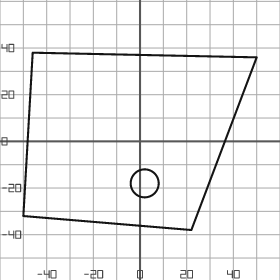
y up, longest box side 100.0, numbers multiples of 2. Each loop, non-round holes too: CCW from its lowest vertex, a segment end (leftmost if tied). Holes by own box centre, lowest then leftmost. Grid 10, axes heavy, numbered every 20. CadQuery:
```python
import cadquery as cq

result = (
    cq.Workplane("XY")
    .moveTo(22.0, -38.0)
    .lineTo(50.0, 36.0)
    .lineTo(-46.0, 38.0)
    .lineTo(-50.0, -32.0)
    .close()
    .moveTo(2.0, -18.0)
    .circle(6.0)
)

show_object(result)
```